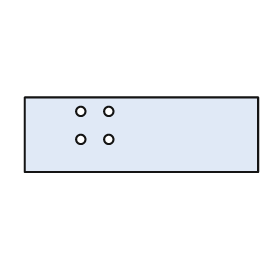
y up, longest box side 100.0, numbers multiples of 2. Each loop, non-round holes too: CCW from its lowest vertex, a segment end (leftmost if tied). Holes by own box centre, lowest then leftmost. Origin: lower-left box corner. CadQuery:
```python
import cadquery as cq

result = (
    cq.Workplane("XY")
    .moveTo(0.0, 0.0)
    .lineTo(100.0, 0.0)
    .lineTo(100.0, 32.0)
    .lineTo(0.0, 32.0)
    .close()
    .moveTo(24.0, 14.0)
    .circle(2.0)
    .moveTo(36.0, 14.0)
    .circle(2.0)
    .moveTo(24.0, 26.0)
    .circle(2.0)
    .moveTo(36.0, 26.0)
    .circle(2.0)
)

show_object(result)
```